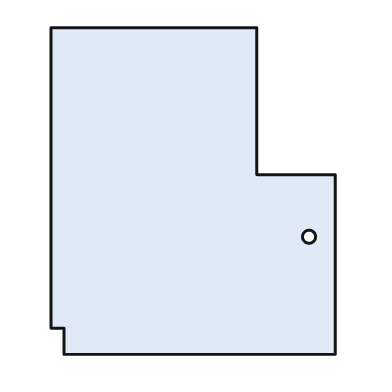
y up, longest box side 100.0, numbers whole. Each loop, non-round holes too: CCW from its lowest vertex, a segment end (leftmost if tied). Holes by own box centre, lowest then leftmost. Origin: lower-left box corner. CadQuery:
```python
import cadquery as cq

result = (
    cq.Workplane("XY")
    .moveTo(4.0, 0.0)
    .lineTo(87.0, 0.0)
    .lineTo(87.0, 55.0)
    .lineTo(63.0, 55.0)
    .lineTo(63.0, 100.0)
    .lineTo(0.0, 100.0)
    .lineTo(0.0, 8.0)
    .lineTo(4.0, 8.0)
    .close()
    .moveTo(79.0, 36.0)
    .circle(2.0)
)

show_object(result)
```